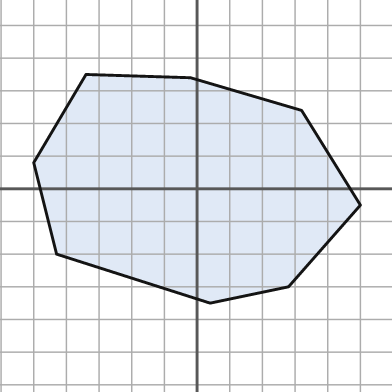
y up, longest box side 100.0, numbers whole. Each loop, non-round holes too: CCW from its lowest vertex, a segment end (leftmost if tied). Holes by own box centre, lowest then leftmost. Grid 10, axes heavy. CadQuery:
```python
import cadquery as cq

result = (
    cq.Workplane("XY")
    .moveTo(4.0, -35.0)
    .lineTo(28.0, -30.0)
    .lineTo(50.0, -5.0)
    .lineTo(32.0, 24.0)
    .lineTo(-2.0, 34.0)
    .lineTo(-34.0, 35.0)
    .lineTo(-50.0, 8.0)
    .lineTo(-43.0, -20.0)
    .close()
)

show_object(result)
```